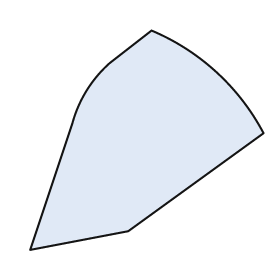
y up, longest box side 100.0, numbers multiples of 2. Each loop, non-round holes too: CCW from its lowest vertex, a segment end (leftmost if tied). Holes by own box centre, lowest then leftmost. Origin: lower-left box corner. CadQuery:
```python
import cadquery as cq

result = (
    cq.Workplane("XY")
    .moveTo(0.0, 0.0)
    .lineTo(42.0, 8.0)
    .lineTo(100.0, 50.0)
    .threePointArc((80.0, 76.0), (52.0, 94.0))
    .lineTo(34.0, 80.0)
    .threePointArc((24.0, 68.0), (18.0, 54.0))
    .close()
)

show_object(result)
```